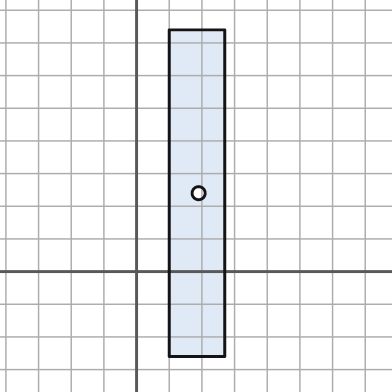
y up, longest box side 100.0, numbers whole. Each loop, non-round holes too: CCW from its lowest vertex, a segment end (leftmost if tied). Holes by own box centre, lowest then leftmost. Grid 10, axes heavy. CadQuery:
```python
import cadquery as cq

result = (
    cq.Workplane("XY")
    .moveTo(10.0, -26.0)
    .lineTo(27.0, -26.0)
    .lineTo(27.0, 74.0)
    .lineTo(10.0, 74.0)
    .close()
    .moveTo(19.0, 24.0)
    .circle(2.0)
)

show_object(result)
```